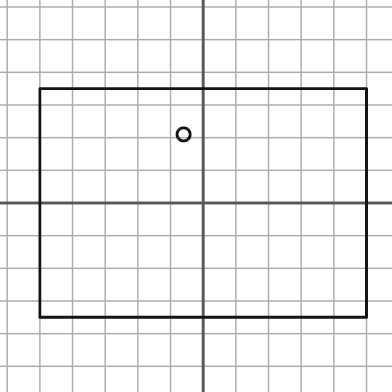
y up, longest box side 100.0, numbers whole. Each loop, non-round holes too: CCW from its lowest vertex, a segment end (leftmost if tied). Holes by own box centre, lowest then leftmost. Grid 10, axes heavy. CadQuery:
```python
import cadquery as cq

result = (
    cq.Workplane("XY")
    .moveTo(-50.0, -35.0)
    .lineTo(50.0, -35.0)
    .lineTo(50.0, 35.0)
    .lineTo(-50.0, 35.0)
    .close()
    .moveTo(-6.0, 21.0)
    .circle(2.0)
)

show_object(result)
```